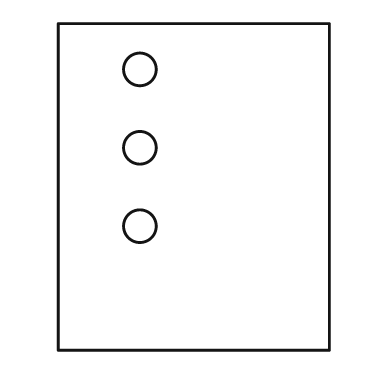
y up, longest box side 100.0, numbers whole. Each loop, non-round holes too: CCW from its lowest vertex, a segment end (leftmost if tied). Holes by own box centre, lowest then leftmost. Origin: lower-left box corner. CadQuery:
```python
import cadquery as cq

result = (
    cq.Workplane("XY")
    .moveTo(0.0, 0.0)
    .lineTo(83.0, 0.0)
    .lineTo(83.0, 100.0)
    .lineTo(0.0, 100.0)
    .close()
    .moveTo(25.0, 38.0)
    .circle(5.0)
    .moveTo(25.0, 62.0)
    .circle(5.0)
    .moveTo(25.0, 86.0)
    .circle(5.0)
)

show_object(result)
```